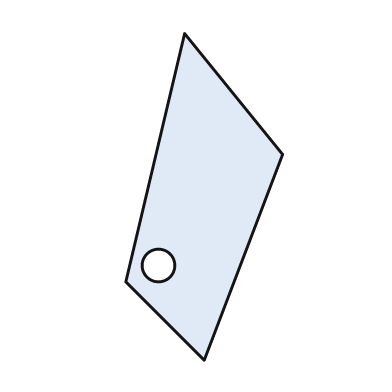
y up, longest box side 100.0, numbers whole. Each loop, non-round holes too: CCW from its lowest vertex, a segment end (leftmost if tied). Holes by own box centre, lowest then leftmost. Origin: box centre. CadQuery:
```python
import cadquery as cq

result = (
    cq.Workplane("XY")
    .moveTo(0.0, -50.0)
    .lineTo(24.0, 13.0)
    .lineTo(-6.0, 50.0)
    .lineTo(-24.0, -26.0)
    .close()
    .moveTo(-14.0, -21.0)
    .circle(5.0)
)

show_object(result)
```